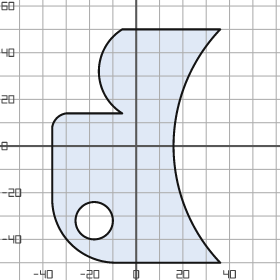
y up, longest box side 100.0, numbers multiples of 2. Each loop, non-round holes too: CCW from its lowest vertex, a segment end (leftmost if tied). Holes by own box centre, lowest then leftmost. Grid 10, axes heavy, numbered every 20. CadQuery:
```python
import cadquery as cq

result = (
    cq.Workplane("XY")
    .moveTo(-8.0, -50.0)
    .lineTo(36.0, -50.0)
    .threePointArc((16.0, 0.0), (36.0, 50.0))
    .lineTo(-6.0, 50.0)
    .threePointArc((-16.0, 32.0), (-6.0, 14.0))
    .lineTo(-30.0, 14.0)
    .threePointArc((-34.0, 12.0), (-36.0, 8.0))
    .lineTo(-36.0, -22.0)
    .threePointArc((-28.0, -42.0), (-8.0, -50.0))
    .close()
    .moveTo(-18.0, -32.0)
    .circle(8.0)
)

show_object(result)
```